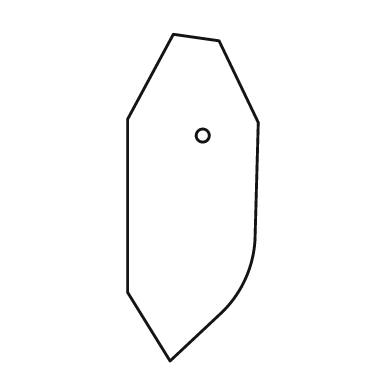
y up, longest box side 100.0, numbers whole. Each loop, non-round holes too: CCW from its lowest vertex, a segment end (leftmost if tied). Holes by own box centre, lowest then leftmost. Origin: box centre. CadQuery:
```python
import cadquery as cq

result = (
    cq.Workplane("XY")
    .moveTo(-7.0, -50.0)
    .lineTo(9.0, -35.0)
    .threePointArc((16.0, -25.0), (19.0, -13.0))
    .lineTo(20.0, 23.0)
    .lineTo(8.0, 48.0)
    .lineTo(-6.0, 50.0)
    .lineTo(-20.0, 24.0)
    .lineTo(-20.0, -29.0)
    .close()
    .moveTo(3.0, 19.0)
    .circle(2.0)
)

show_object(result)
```